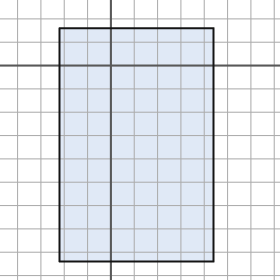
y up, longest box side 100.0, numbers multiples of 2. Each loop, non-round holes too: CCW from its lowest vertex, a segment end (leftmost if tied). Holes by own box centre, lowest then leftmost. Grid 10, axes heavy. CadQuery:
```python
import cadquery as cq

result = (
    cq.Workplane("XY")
    .moveTo(-22.0, -84.0)
    .lineTo(44.0, -84.0)
    .lineTo(44.0, 16.0)
    .lineTo(-22.0, 16.0)
    .close()
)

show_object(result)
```